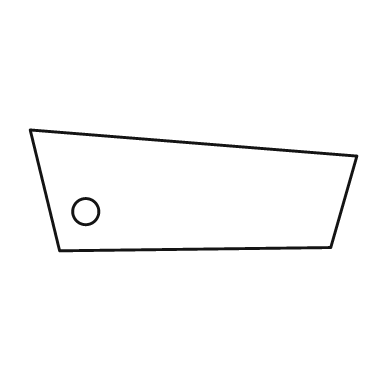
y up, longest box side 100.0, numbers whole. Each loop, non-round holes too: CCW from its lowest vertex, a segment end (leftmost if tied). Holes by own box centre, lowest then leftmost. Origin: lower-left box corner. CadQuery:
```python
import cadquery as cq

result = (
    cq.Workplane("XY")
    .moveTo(9.0, 0.0)
    .lineTo(92.0, 1.0)
    .lineTo(100.0, 29.0)
    .lineTo(0.0, 37.0)
    .close()
    .moveTo(17.0, 12.0)
    .circle(4.0)
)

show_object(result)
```